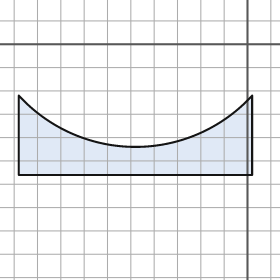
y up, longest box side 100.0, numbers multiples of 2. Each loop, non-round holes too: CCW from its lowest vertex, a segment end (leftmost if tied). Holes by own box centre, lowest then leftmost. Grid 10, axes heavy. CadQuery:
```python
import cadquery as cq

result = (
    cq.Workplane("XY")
    .moveTo(-98.0, -56.0)
    .lineTo(2.0, -56.0)
    .lineTo(2.0, -22.0)
    .threePointArc((-48.0, -44.0), (-98.0, -22.0))
    .close()
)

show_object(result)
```